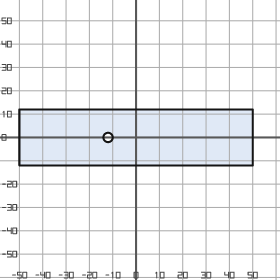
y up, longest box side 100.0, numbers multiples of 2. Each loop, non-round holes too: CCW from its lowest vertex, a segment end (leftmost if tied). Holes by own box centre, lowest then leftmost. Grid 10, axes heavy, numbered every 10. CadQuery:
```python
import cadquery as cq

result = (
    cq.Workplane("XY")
    .moveTo(-50.0, -12.0)
    .lineTo(50.0, -12.0)
    .lineTo(50.0, 12.0)
    .lineTo(-50.0, 12.0)
    .close()
    .moveTo(-12.0, 0.0)
    .circle(2.0)
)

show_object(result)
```